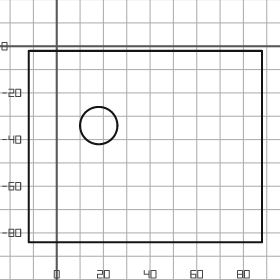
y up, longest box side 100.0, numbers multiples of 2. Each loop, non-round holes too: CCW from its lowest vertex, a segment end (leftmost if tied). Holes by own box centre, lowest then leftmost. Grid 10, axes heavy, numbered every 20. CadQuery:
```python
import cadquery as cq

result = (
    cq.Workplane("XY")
    .moveTo(-12.0, -84.0)
    .lineTo(88.0, -84.0)
    .lineTo(88.0, -2.0)
    .lineTo(-12.0, -2.0)
    .close()
    .moveTo(18.0, -34.0)
    .circle(8.0)
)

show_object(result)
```